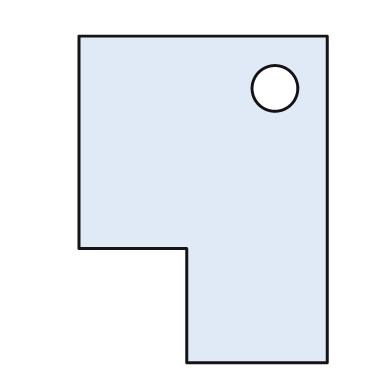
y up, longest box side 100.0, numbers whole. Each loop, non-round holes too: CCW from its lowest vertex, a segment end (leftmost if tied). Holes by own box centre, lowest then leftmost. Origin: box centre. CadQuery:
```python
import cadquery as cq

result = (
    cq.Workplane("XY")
    .moveTo(-5.0, -50.0)
    .lineTo(38.0, -50.0)
    .lineTo(38.0, 50.0)
    .lineTo(-38.0, 50.0)
    .lineTo(-38.0, -15.0)
    .lineTo(-5.0, -15.0)
    .close()
    .moveTo(22.0, 34.0)
    .circle(7.0)
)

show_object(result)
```